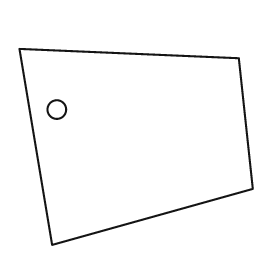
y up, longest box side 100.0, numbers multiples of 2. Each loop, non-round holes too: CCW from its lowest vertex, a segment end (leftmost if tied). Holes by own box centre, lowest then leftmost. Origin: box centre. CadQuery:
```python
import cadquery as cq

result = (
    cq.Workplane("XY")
    .moveTo(-36.0, -42.0)
    .lineTo(50.0, -18.0)
    .lineTo(44.0, 38.0)
    .lineTo(-50.0, 42.0)
    .close()
    .moveTo(-34.0, 16.0)
    .circle(4.0)
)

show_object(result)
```